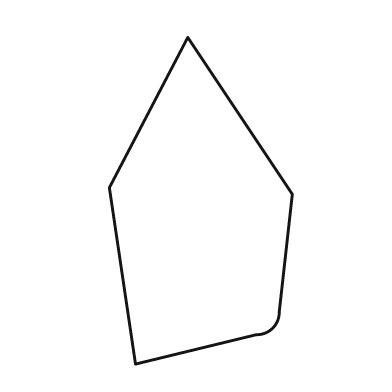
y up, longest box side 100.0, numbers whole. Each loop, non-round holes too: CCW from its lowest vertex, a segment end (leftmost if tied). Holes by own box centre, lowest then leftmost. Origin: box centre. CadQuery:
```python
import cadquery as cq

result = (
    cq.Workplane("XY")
    .moveTo(-20.0, -50.0)
    .lineTo(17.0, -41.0)
    .threePointArc((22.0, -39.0), (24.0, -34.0))
    .lineTo(28.0, 2.0)
    .lineTo(-4.0, 50.0)
    .lineTo(-28.0, 4.0)
    .close()
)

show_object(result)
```